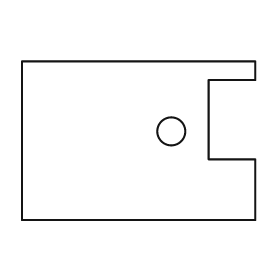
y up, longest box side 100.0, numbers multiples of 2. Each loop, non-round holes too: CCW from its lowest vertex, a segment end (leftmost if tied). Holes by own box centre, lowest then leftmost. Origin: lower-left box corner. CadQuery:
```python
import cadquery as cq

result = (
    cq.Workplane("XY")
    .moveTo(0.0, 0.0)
    .lineTo(100.0, 0.0)
    .lineTo(100.0, 26.0)
    .lineTo(80.0, 26.0)
    .lineTo(80.0, 60.0)
    .lineTo(100.0, 60.0)
    .lineTo(100.0, 68.0)
    .lineTo(0.0, 68.0)
    .close()
    .moveTo(64.0, 38.0)
    .circle(6.0)
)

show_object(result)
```